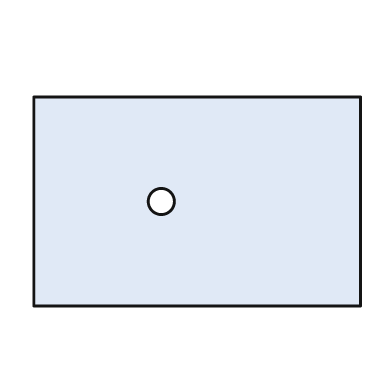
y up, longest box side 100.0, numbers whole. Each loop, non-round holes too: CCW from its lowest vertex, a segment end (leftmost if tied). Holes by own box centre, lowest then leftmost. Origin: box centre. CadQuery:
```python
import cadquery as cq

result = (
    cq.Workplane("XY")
    .moveTo(-50.0, -32.0)
    .lineTo(50.0, -32.0)
    .lineTo(50.0, 32.0)
    .lineTo(-50.0, 32.0)
    .close()
    .moveTo(-11.0, 0.0)
    .circle(4.0)
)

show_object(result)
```